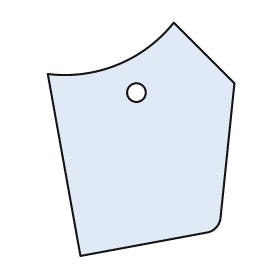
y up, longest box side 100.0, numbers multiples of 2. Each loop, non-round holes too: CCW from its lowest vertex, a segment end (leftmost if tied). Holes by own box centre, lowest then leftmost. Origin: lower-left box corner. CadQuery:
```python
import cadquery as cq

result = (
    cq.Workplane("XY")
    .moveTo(14.0, 0.0)
    .lineTo(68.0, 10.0)
    .threePointArc((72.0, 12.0), (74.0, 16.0))
    .lineTo(80.0, 74.0)
    .lineTo(54.0, 100.0)
    .threePointArc((30.0, 82.0), (0.0, 78.0))
    .close()
    .moveTo(38.0, 70.0)
    .circle(4.0)
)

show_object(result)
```